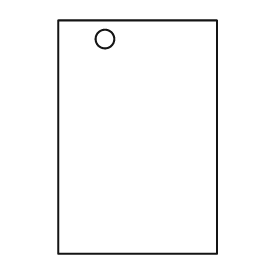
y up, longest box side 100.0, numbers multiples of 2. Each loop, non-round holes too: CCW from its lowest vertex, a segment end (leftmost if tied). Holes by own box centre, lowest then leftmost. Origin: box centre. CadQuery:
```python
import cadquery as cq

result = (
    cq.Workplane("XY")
    .moveTo(-34.0, -50.0)
    .lineTo(34.0, -50.0)
    .lineTo(34.0, 50.0)
    .lineTo(-34.0, 50.0)
    .close()
    .moveTo(-14.0, 42.0)
    .circle(4.0)
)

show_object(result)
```